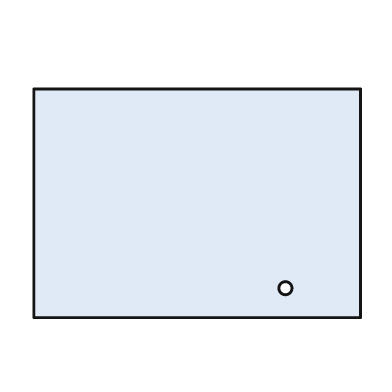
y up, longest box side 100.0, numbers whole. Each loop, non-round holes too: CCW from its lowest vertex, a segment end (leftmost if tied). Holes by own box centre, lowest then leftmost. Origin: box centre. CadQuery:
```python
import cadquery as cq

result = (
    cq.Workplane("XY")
    .moveTo(-50.0, -35.0)
    .lineTo(50.0, -35.0)
    .lineTo(50.0, 35.0)
    .lineTo(-50.0, 35.0)
    .close()
    .moveTo(27.0, -26.0)
    .circle(2.0)
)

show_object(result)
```